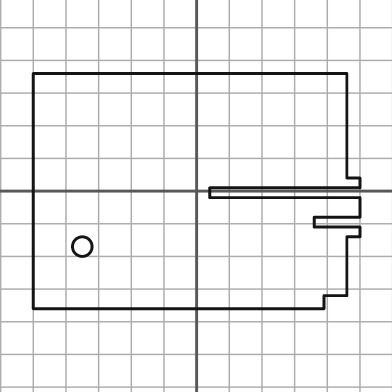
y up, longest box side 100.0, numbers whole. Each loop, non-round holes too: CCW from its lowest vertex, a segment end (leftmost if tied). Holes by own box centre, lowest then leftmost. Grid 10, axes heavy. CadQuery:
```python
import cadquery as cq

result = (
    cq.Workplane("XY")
    .moveTo(-50.0, -36.0)
    .lineTo(39.0, -36.0)
    .lineTo(39.0, -32.0)
    .lineTo(46.0, -32.0)
    .lineTo(46.0, -14.0)
    .lineTo(50.0, -14.0)
    .lineTo(50.0, -11.0)
    .lineTo(36.0, -11.0)
    .lineTo(36.0, -8.0)
    .lineTo(50.0, -8.0)
    .lineTo(50.0, -2.0)
    .lineTo(4.0, -2.0)
    .lineTo(4.0, 1.0)
    .lineTo(50.0, 1.0)
    .lineTo(50.0, 4.0)
    .lineTo(46.0, 4.0)
    .lineTo(46.0, 36.0)
    .lineTo(-50.0, 36.0)
    .close()
    .moveTo(-35.0, -17.0)
    .circle(3.0)
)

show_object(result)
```